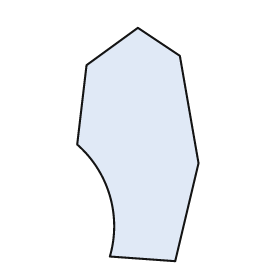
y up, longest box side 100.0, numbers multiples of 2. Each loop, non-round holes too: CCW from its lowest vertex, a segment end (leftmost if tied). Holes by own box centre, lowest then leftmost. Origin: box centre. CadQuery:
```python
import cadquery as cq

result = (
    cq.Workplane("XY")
    .moveTo(16.0, -50.0)
    .lineTo(26.0, -8.0)
    .lineTo(18.0, 38.0)
    .lineTo(0.0, 50.0)
    .lineTo(-22.0, 34.0)
    .lineTo(-26.0, 0.0)
    .threePointArc((-12.0, -22.0), (-12.0, -48.0))
    .close()
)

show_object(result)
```